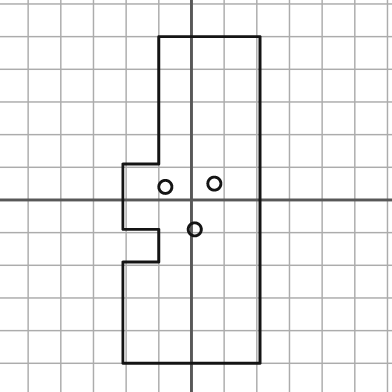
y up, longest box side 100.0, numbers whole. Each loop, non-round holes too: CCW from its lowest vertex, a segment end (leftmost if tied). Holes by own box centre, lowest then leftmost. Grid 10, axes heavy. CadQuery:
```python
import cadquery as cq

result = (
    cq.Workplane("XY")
    .moveTo(-21.0, -50.0)
    .lineTo(21.0, -50.0)
    .lineTo(21.0, 50.0)
    .lineTo(-10.0, 50.0)
    .lineTo(-10.0, 11.0)
    .lineTo(-21.0, 11.0)
    .lineTo(-21.0, -9.0)
    .lineTo(-10.0, -9.0)
    .lineTo(-10.0, -19.0)
    .lineTo(-21.0, -19.0)
    .close()
    .moveTo(1.0, -9.0)
    .circle(2.0)
    .moveTo(-8.0, 4.0)
    .circle(2.0)
    .moveTo(7.0, 5.0)
    .circle(2.0)
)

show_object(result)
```